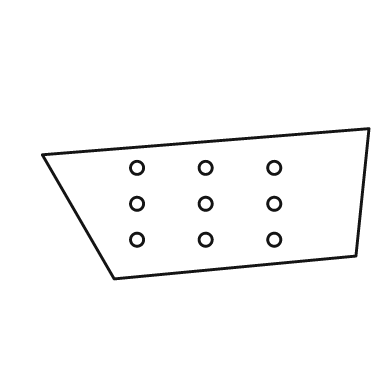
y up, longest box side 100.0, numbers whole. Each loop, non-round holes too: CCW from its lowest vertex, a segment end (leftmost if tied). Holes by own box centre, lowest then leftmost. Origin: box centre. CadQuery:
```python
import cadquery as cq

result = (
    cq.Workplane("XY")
    .moveTo(-28.0, -23.0)
    .lineTo(46.0, -16.0)
    .lineTo(50.0, 23.0)
    .lineTo(-50.0, 15.0)
    .close()
    .moveTo(-21.0, -11.0)
    .circle(2.0)
    .moveTo(0.0, -11.0)
    .circle(2.0)
    .moveTo(21.0, -11.0)
    .circle(2.0)
    .moveTo(-21.0, 0.0)
    .circle(2.0)
    .moveTo(0.0, 0.0)
    .circle(2.0)
    .moveTo(21.0, 0.0)
    .circle(2.0)
    .moveTo(-21.0, 11.0)
    .circle(2.0)
    .moveTo(0.0, 11.0)
    .circle(2.0)
    .moveTo(21.0, 11.0)
    .circle(2.0)
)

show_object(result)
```